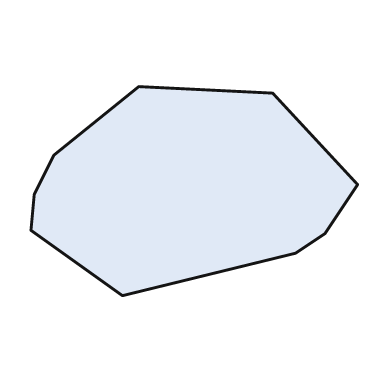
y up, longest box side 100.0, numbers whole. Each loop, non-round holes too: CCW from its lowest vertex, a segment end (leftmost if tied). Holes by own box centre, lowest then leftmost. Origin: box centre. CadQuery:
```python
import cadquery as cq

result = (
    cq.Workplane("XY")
    .moveTo(-22.0, -32.0)
    .lineTo(31.0, -19.0)
    .lineTo(40.0, -13.0)
    .lineTo(50.0, 2.0)
    .lineTo(24.0, 30.0)
    .lineTo(-17.0, 32.0)
    .lineTo(-43.0, 11.0)
    .lineTo(-49.0, -1.0)
    .lineTo(-50.0, -12.0)
    .close()
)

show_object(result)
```